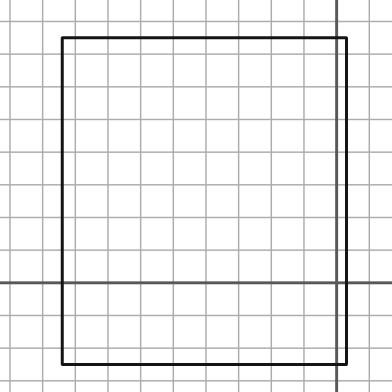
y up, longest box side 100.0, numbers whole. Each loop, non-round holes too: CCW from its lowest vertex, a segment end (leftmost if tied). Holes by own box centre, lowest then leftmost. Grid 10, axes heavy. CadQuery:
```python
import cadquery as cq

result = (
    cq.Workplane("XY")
    .moveTo(-84.0, -25.0)
    .lineTo(3.0, -25.0)
    .lineTo(3.0, 75.0)
    .lineTo(-84.0, 75.0)
    .close()
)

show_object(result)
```